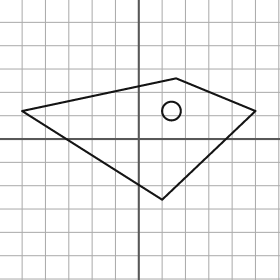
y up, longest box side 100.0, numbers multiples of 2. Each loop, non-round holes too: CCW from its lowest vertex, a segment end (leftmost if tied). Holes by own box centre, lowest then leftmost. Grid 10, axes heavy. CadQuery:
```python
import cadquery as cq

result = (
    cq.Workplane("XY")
    .moveTo(10.0, -26.0)
    .lineTo(50.0, 12.0)
    .lineTo(16.0, 26.0)
    .lineTo(-50.0, 12.0)
    .close()
    .moveTo(14.0, 12.0)
    .circle(4.0)
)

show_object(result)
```